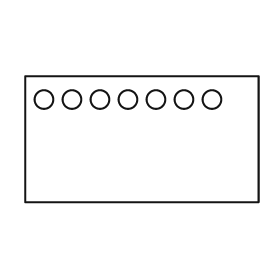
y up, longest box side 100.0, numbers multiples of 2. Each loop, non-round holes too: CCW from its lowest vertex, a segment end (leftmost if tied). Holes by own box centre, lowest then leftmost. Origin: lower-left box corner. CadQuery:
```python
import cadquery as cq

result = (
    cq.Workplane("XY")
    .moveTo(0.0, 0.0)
    .lineTo(100.0, 0.0)
    .lineTo(100.0, 54.0)
    .lineTo(0.0, 54.0)
    .close()
    .moveTo(8.0, 44.0)
    .circle(4.0)
    .moveTo(20.0, 44.0)
    .circle(4.0)
    .moveTo(32.0, 44.0)
    .circle(4.0)
    .moveTo(44.0, 44.0)
    .circle(4.0)
    .moveTo(56.0, 44.0)
    .circle(4.0)
    .moveTo(68.0, 44.0)
    .circle(4.0)
    .moveTo(80.0, 44.0)
    .circle(4.0)
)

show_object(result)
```